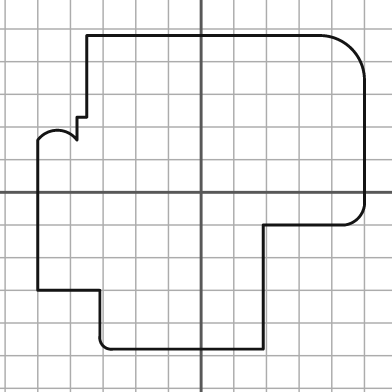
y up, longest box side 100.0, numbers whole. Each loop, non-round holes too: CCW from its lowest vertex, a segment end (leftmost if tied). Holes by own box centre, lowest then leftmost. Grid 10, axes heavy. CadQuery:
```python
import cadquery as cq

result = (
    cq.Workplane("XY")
    .moveTo(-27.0, -48.0)
    .lineTo(19.0, -48.0)
    .lineTo(19.0, -10.0)
    .lineTo(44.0, -10.0)
    .threePointArc((48.0, -8.0), (50.0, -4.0))
    .lineTo(50.0, 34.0)
    .threePointArc((46.0, 44.0), (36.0, 48.0))
    .lineTo(-35.0, 48.0)
    .lineTo(-35.0, 23.0)
    .lineTo(-38.0, 23.0)
    .lineTo(-38.0, 16.0)
    .threePointArc((-44.0, 19.0), (-50.0, 16.0))
    .lineTo(-50.0, -30.0)
    .lineTo(-31.0, -30.0)
    .lineTo(-31.0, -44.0)
    .threePointArc((-30.0, -47.0), (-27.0, -48.0))
    .close()
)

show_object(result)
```